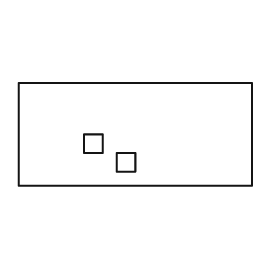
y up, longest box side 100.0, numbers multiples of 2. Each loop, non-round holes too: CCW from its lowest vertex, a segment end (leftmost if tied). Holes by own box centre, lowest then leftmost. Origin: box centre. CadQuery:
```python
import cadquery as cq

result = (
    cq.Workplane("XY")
    .moveTo(-50.0, -22.0)
    .lineTo(50.0, -22.0)
    .lineTo(50.0, 22.0)
    .lineTo(-50.0, 22.0)
    .close()
    .moveTo(-8.0, -16.0)
    .lineTo(0.0, -16.0)
    .lineTo(0.0, -8.0)
    .lineTo(-8.0, -8.0)
    .close()
    .moveTo(-22.0, -8.0)
    .lineTo(-14.0, -8.0)
    .lineTo(-14.0, 0.0)
    .lineTo(-22.0, 0.0)
    .close()
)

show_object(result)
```